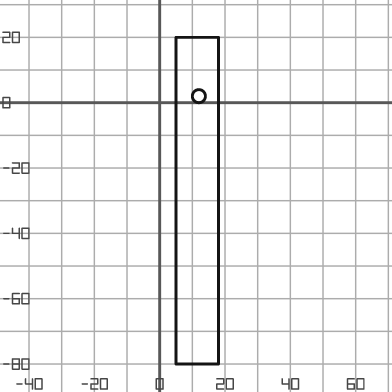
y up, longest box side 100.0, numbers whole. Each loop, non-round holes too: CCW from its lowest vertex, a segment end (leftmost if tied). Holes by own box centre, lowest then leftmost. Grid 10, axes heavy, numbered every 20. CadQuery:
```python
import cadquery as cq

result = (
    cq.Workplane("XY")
    .moveTo(5.0, -80.0)
    .lineTo(18.0, -80.0)
    .lineTo(18.0, 20.0)
    .lineTo(5.0, 20.0)
    .close()
    .moveTo(12.0, 2.0)
    .circle(2.0)
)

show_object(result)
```